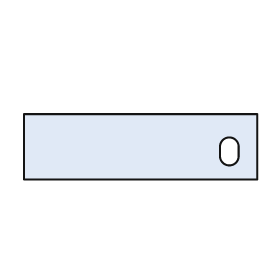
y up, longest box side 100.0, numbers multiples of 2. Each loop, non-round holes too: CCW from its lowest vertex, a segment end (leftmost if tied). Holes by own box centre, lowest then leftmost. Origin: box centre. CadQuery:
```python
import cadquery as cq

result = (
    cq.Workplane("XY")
    .moveTo(-50.0, -14.0)
    .lineTo(50.0, -14.0)
    .lineTo(50.0, 14.0)
    .lineTo(-50.0, 14.0)
    .close()
    .moveTo(34.0, -4.0)
    .threePointArc((38.0, -8.0), (42.0, -4.0))
    .lineTo(42.0, 0.0)
    .threePointArc((38.0, 4.0), (34.0, 0.0))
    .close()
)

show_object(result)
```